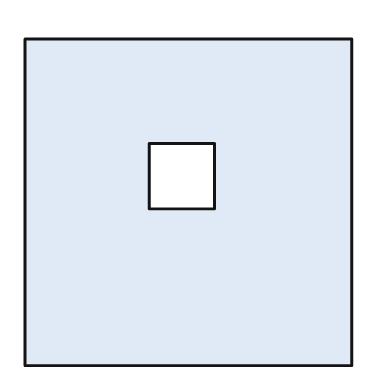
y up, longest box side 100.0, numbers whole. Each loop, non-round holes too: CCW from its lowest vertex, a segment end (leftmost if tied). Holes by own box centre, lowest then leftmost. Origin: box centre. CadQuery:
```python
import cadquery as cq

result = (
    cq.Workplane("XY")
    .moveTo(-50.0, -50.0)
    .lineTo(50.0, -50.0)
    .lineTo(50.0, 50.0)
    .lineTo(-50.0, 50.0)
    .close()
    .moveTo(-12.0, -2.0)
    .lineTo(8.0, -2.0)
    .lineTo(8.0, 18.0)
    .lineTo(-12.0, 18.0)
    .close()
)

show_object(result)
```